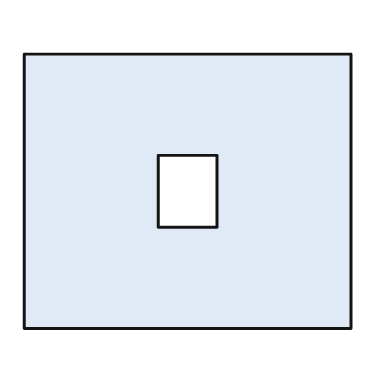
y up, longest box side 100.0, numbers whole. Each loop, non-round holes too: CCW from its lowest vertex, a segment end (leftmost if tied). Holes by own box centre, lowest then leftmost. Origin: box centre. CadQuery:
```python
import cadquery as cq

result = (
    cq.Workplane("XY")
    .moveTo(-50.0, -42.0)
    .lineTo(50.0, -42.0)
    .lineTo(50.0, 42.0)
    .lineTo(-50.0, 42.0)
    .close()
    .moveTo(-9.0, -11.0)
    .lineTo(9.0, -11.0)
    .lineTo(9.0, 11.0)
    .lineTo(-9.0, 11.0)
    .close()
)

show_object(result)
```